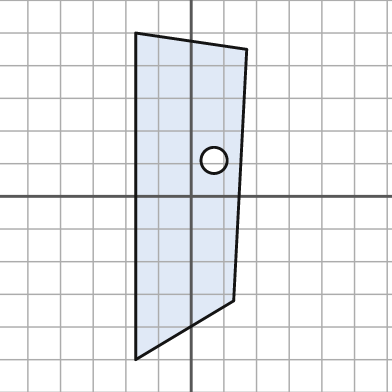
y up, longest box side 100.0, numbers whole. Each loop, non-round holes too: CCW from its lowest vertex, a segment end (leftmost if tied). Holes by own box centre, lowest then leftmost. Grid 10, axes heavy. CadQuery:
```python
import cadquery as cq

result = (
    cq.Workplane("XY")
    .moveTo(-17.0, -50.0)
    .lineTo(13.0, -32.0)
    .lineTo(17.0, 45.0)
    .lineTo(-17.0, 50.0)
    .close()
    .moveTo(7.0, 11.0)
    .circle(4.0)
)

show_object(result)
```